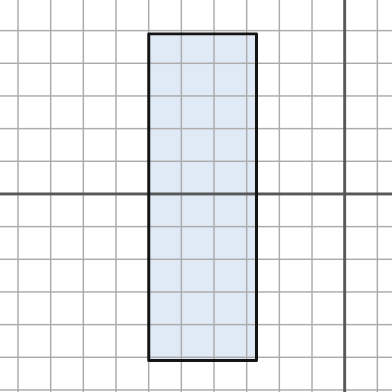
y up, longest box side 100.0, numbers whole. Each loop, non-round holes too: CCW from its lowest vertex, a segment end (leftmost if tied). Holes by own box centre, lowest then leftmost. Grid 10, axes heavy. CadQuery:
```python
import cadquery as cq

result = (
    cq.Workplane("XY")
    .moveTo(-60.0, -51.0)
    .lineTo(-27.0, -51.0)
    .lineTo(-27.0, 49.0)
    .lineTo(-60.0, 49.0)
    .close()
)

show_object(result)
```